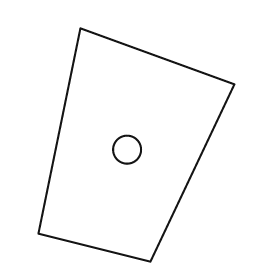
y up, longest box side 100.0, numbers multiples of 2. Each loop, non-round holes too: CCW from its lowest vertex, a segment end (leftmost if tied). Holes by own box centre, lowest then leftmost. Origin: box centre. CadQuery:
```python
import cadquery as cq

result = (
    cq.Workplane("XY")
    .moveTo(6.0, -50.0)
    .lineTo(42.0, 26.0)
    .lineTo(-24.0, 50.0)
    .lineTo(-42.0, -38.0)
    .close()
    .moveTo(-4.0, -2.0)
    .circle(6.0)
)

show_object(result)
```